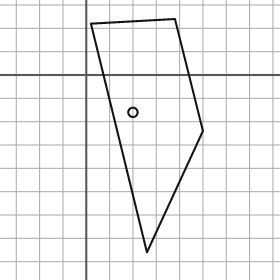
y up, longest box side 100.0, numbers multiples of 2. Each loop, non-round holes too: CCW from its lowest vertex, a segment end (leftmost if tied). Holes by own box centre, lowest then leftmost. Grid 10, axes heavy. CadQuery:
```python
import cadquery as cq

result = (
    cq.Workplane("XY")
    .moveTo(26.0, -76.0)
    .lineTo(50.0, -24.0)
    .lineTo(38.0, 24.0)
    .lineTo(2.0, 22.0)
    .close()
    .moveTo(20.0, -16.0)
    .circle(2.0)
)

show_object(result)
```